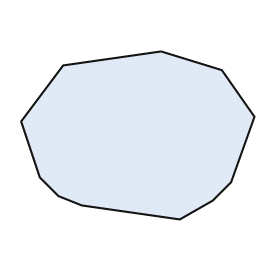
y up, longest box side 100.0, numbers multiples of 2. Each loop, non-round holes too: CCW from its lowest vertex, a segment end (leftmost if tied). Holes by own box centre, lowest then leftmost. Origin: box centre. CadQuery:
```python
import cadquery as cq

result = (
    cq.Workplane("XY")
    .moveTo(18.0, -36.0)
    .lineTo(32.0, -28.0)
    .lineTo(40.0, -20.0)
    .lineTo(50.0, 8.0)
    .lineTo(36.0, 28.0)
    .lineTo(10.0, 36.0)
    .lineTo(-32.0, 30.0)
    .lineTo(-50.0, 6.0)
    .lineTo(-42.0, -18.0)
    .lineTo(-34.0, -26.0)
    .lineTo(-24.0, -30.0)
    .close()
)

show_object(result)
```